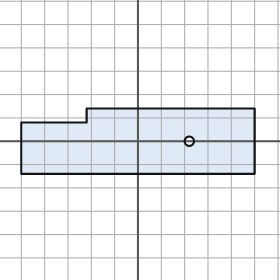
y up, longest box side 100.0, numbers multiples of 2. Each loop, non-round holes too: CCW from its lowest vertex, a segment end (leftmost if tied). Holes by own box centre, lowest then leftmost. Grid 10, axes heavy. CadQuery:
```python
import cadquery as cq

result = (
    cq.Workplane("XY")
    .moveTo(-50.0, -14.0)
    .lineTo(50.0, -14.0)
    .lineTo(50.0, 14.0)
    .lineTo(-22.0, 14.0)
    .lineTo(-22.0, 8.0)
    .lineTo(-50.0, 8.0)
    .close()
    .moveTo(22.0, 0.0)
    .circle(2.0)
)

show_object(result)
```